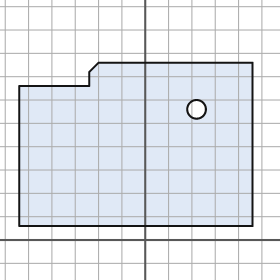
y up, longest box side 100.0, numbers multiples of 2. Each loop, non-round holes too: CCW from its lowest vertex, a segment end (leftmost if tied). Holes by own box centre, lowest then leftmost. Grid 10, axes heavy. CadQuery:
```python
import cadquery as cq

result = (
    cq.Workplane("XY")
    .moveTo(-54.0, 6.0)
    .lineTo(46.0, 6.0)
    .lineTo(46.0, 76.0)
    .lineTo(-20.0, 76.0)
    .lineTo(-24.0, 72.0)
    .lineTo(-24.0, 66.0)
    .lineTo(-54.0, 66.0)
    .close()
    .moveTo(22.0, 56.0)
    .circle(4.0)
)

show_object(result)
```